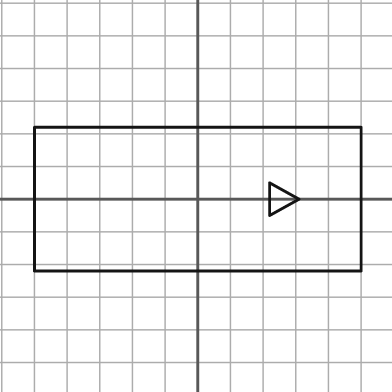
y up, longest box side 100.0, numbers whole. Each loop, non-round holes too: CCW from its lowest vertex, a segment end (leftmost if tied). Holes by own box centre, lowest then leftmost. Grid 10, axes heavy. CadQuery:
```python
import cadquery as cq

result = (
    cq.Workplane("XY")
    .moveTo(-50.0, -22.0)
    .lineTo(50.0, -22.0)
    .lineTo(50.0, 22.0)
    .lineTo(-50.0, 22.0)
    .close()
    .moveTo(22.0, -5.0)
    .lineTo(31.0, 0.0)
    .lineTo(22.0, 5.0)
    .close()
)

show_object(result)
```